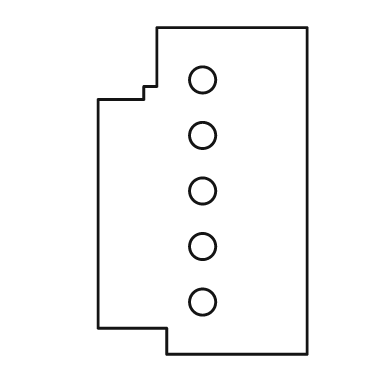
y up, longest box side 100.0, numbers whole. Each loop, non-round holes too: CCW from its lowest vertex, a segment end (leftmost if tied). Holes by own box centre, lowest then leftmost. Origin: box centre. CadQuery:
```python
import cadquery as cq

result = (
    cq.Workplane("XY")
    .moveTo(-11.0, -50.0)
    .lineTo(32.0, -50.0)
    .lineTo(32.0, 50.0)
    .lineTo(-14.0, 50.0)
    .lineTo(-14.0, 32.0)
    .lineTo(-18.0, 32.0)
    .lineTo(-18.0, 28.0)
    .lineTo(-32.0, 28.0)
    .lineTo(-32.0, -42.0)
    .lineTo(-11.0, -42.0)
    .close()
    .moveTo(0.0, -34.0)
    .circle(4.0)
    .moveTo(0.0, -17.0)
    .circle(4.0)
    .moveTo(0.0, 0.0)
    .circle(4.0)
    .moveTo(0.0, 17.0)
    .circle(4.0)
    .moveTo(0.0, 34.0)
    .circle(4.0)
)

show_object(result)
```